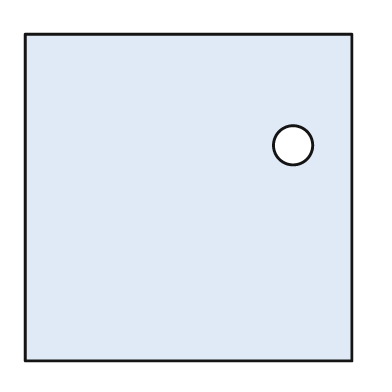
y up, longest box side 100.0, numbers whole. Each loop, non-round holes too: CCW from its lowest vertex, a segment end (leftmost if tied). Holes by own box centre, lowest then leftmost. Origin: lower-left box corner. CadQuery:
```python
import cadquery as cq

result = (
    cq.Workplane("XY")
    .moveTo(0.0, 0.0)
    .lineTo(100.0, 0.0)
    .lineTo(100.0, 100.0)
    .lineTo(0.0, 100.0)
    .close()
    .moveTo(82.0, 66.0)
    .circle(6.0)
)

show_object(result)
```